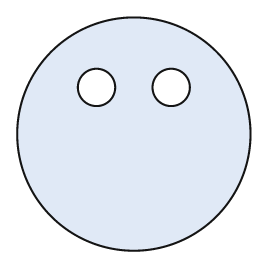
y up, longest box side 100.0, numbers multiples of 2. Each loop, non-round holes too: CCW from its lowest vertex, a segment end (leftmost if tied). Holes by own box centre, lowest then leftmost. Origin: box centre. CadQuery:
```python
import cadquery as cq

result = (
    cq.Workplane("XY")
    .moveTo(0.0, 0.0)
    .circle(50.0)
    .moveTo(-16.0, 20.0)
    .circle(8.0)
    .moveTo(16.0, 20.0)
    .circle(8.0)
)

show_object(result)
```